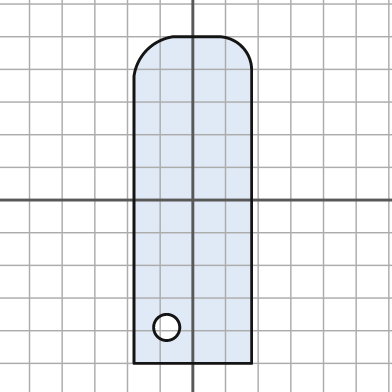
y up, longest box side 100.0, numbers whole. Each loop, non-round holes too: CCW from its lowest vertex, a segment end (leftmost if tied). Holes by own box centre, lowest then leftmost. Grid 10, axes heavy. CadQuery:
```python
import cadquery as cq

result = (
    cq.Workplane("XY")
    .moveTo(-18.0, -50.0)
    .lineTo(18.0, -50.0)
    .lineTo(18.0, 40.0)
    .threePointArc((15.0, 47.0), (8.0, 50.0))
    .lineTo(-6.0, 50.0)
    .threePointArc((-14.0, 46.0), (-18.0, 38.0))
    .close()
    .moveTo(-8.0, -39.0)
    .circle(4.0)
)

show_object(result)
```